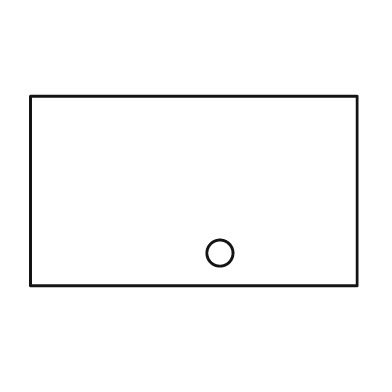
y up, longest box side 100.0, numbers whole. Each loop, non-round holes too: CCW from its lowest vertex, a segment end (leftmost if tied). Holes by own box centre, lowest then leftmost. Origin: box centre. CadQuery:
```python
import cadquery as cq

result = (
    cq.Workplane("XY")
    .moveTo(-50.0, -29.0)
    .lineTo(50.0, -29.0)
    .lineTo(50.0, 29.0)
    .lineTo(-50.0, 29.0)
    .close()
    .moveTo(8.0, -19.0)
    .circle(4.0)
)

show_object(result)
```